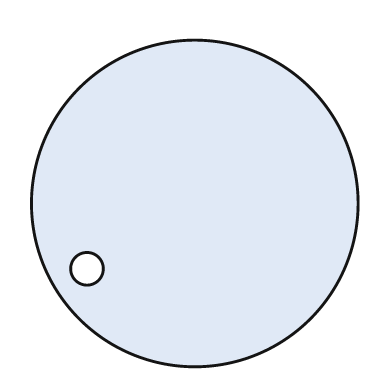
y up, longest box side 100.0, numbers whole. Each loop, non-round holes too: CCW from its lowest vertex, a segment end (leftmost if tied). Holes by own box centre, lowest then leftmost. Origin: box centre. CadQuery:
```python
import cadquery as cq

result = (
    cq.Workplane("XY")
    .moveTo(0.0, 0.0)
    .circle(50.0)
    .moveTo(-33.0, -20.0)
    .circle(5.0)
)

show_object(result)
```